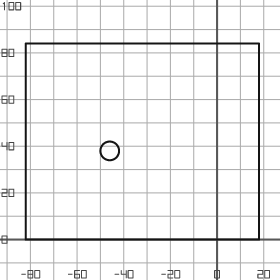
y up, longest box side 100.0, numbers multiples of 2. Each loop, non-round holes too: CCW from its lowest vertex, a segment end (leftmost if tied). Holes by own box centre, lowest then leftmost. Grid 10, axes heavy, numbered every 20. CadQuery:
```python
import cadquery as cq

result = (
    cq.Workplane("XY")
    .moveTo(-82.0, 0.0)
    .lineTo(18.0, 0.0)
    .lineTo(18.0, 84.0)
    .lineTo(-82.0, 84.0)
    .close()
    .moveTo(-46.0, 38.0)
    .circle(4.0)
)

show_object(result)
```